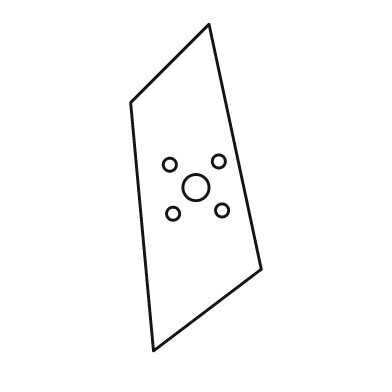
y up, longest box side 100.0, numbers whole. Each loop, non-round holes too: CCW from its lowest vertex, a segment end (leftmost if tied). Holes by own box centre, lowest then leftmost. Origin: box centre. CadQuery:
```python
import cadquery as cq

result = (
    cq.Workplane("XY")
    .moveTo(-13.0, -50.0)
    .lineTo(20.0, -25.0)
    .lineTo(4.0, 50.0)
    .lineTo(-20.0, 26.0)
    .close()
    .moveTo(-7.0, -8.0)
    .circle(2.0)
    .moveTo(8.0, -7.0)
    .circle(2.0)
    .moveTo(0.0, 0.0)
    .circle(4.0)
    .moveTo(-8.0, 7.0)
    .circle(2.0)
    .moveTo(7.0, 8.0)
    .circle(2.0)
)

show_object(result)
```